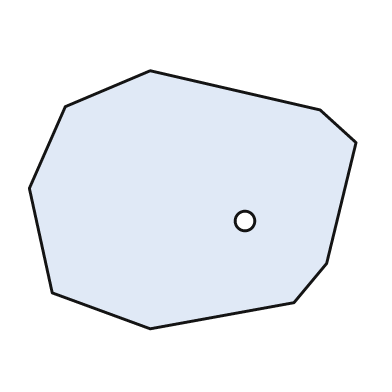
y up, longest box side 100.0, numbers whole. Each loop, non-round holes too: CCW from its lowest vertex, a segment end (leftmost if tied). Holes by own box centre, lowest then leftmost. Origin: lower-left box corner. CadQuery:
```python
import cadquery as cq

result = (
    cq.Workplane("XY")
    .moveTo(37.0, 0.0)
    .lineTo(81.0, 8.0)
    .lineTo(91.0, 20.0)
    .lineTo(100.0, 57.0)
    .lineTo(89.0, 67.0)
    .lineTo(37.0, 79.0)
    .lineTo(11.0, 68.0)
    .lineTo(0.0, 43.0)
    .lineTo(7.0, 11.0)
    .close()
    .moveTo(66.0, 33.0)
    .circle(3.0)
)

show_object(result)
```